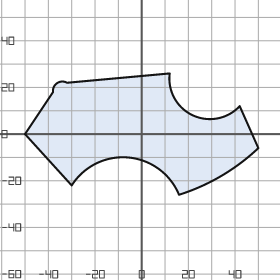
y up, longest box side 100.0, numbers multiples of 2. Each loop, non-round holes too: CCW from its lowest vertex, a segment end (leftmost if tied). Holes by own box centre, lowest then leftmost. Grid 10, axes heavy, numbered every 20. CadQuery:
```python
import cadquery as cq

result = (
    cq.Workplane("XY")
    .moveTo(16.0, -26.0)
    .threePointArc((34.0, -18.0), (50.0, -6.0))
    .lineTo(42.0, 12.0)
    .threePointArc((22.0, 8.0), (12.0, 26.0))
    .lineTo(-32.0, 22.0)
    .threePointArc((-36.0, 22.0), (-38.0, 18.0))
    .lineTo(-50.0, 0.0)
    .lineTo(-30.0, -22.0)
    .threePointArc((-6.0, -10.0), (16.0, -26.0))
    .close()
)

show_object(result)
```